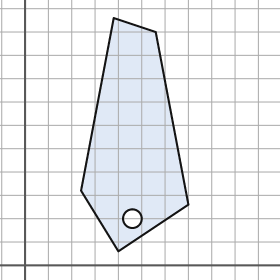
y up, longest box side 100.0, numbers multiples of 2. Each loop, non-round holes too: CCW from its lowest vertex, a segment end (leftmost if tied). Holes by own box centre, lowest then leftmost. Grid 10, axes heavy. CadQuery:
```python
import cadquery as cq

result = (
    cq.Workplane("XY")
    .moveTo(40.0, 6.0)
    .lineTo(70.0, 26.0)
    .lineTo(56.0, 100.0)
    .lineTo(38.0, 106.0)
    .lineTo(24.0, 32.0)
    .close()
    .moveTo(46.0, 20.0)
    .circle(4.0)
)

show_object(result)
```